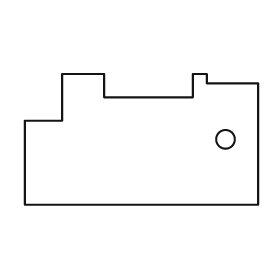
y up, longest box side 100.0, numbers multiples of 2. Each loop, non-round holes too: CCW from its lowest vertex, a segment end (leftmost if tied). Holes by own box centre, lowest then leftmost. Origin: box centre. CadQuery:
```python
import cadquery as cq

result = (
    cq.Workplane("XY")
    .moveTo(-50.0, -28.0)
    .lineTo(50.0, -28.0)
    .lineTo(50.0, 24.0)
    .lineTo(28.0, 24.0)
    .lineTo(28.0, 28.0)
    .lineTo(22.0, 28.0)
    .lineTo(22.0, 18.0)
    .lineTo(-16.0, 18.0)
    .lineTo(-16.0, 28.0)
    .lineTo(-34.0, 28.0)
    .lineTo(-34.0, 8.0)
    .lineTo(-50.0, 8.0)
    .close()
    .moveTo(36.0, 0.0)
    .circle(4.0)
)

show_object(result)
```